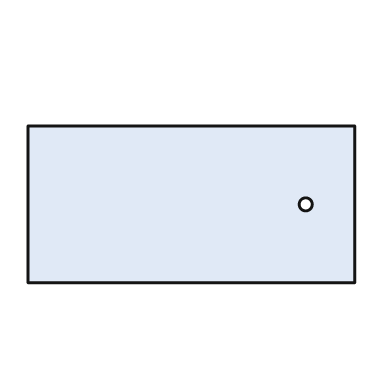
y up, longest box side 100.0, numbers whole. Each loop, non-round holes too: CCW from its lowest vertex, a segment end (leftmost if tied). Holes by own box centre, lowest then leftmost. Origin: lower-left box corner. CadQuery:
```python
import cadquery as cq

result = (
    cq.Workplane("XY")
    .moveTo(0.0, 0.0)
    .lineTo(100.0, 0.0)
    .lineTo(100.0, 48.0)
    .lineTo(0.0, 48.0)
    .close()
    .moveTo(85.0, 24.0)
    .circle(2.0)
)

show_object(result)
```